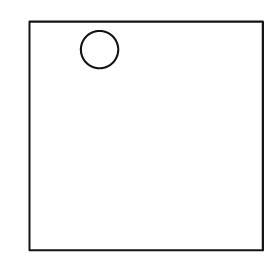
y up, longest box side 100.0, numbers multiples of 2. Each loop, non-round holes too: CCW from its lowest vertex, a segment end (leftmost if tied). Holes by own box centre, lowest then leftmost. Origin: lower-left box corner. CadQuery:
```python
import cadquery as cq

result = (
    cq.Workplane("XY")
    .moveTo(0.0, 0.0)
    .lineTo(100.0, 0.0)
    .lineTo(100.0, 98.0)
    .lineTo(0.0, 98.0)
    .close()
    .moveTo(30.0, 86.0)
    .circle(8.0)
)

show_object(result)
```